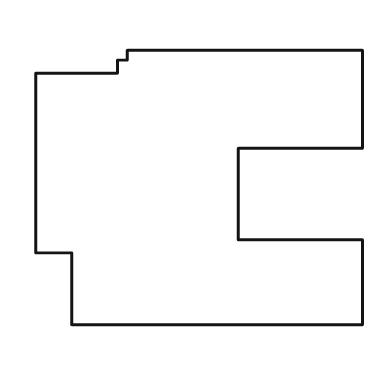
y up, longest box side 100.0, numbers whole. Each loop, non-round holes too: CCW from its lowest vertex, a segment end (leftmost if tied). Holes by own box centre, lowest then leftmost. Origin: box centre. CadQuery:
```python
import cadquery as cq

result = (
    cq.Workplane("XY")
    .moveTo(-39.0, -42.0)
    .lineTo(50.0, -42.0)
    .lineTo(50.0, -16.0)
    .lineTo(12.0, -16.0)
    .lineTo(12.0, 12.0)
    .lineTo(50.0, 12.0)
    .lineTo(50.0, 42.0)
    .lineTo(-22.0, 42.0)
    .lineTo(-22.0, 39.0)
    .lineTo(-25.0, 39.0)
    .lineTo(-25.0, 35.0)
    .lineTo(-50.0, 35.0)
    .lineTo(-50.0, -20.0)
    .lineTo(-39.0, -20.0)
    .close()
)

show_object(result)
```